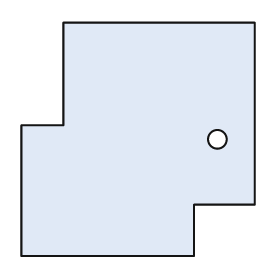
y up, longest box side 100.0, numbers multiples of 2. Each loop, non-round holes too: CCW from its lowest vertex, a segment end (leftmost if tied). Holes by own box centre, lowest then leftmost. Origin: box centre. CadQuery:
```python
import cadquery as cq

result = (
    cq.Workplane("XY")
    .moveTo(-50.0, -50.0)
    .lineTo(24.0, -50.0)
    .lineTo(24.0, -28.0)
    .lineTo(50.0, -28.0)
    .lineTo(50.0, 50.0)
    .lineTo(-32.0, 50.0)
    .lineTo(-32.0, 6.0)
    .lineTo(-50.0, 6.0)
    .close()
    .moveTo(34.0, 0.0)
    .circle(4.0)
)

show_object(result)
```